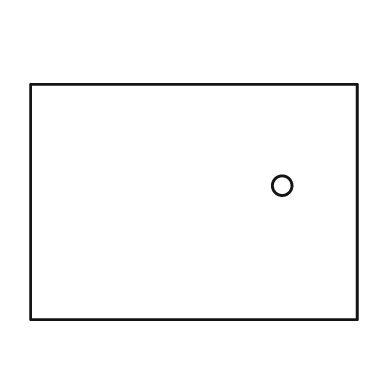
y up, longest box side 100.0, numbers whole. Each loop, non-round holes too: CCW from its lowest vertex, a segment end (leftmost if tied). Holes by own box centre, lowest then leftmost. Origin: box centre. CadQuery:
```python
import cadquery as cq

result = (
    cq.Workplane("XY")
    .moveTo(-50.0, -36.0)
    .lineTo(50.0, -36.0)
    .lineTo(50.0, 36.0)
    .lineTo(-50.0, 36.0)
    .close()
    .moveTo(27.0, 5.0)
    .circle(3.0)
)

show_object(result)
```